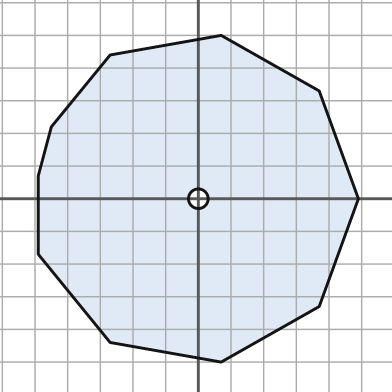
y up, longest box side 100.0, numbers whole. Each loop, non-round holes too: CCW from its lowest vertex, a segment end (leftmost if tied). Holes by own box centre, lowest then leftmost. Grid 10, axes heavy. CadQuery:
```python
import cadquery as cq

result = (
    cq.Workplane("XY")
    .moveTo(7.0, -50.0)
    .lineTo(37.0, -33.0)
    .lineTo(49.0, 0.0)
    .lineTo(37.0, 33.0)
    .lineTo(7.0, 50.0)
    .lineTo(-27.0, 44.0)
    .lineTo(-45.0, 22.0)
    .lineTo(-49.0, 7.0)
    .lineTo(-49.0, -17.0)
    .lineTo(-27.0, -44.0)
    .close()
    .moveTo(0.0, 0.0)
    .circle(3.0)
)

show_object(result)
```